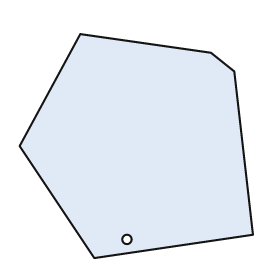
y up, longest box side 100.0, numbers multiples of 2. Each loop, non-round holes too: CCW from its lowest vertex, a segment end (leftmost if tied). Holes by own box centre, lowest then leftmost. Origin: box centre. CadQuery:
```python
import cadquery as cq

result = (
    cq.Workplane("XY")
    .moveTo(-18.0, -48.0)
    .lineTo(50.0, -38.0)
    .lineTo(42.0, 32.0)
    .lineTo(32.0, 40.0)
    .lineTo(-24.0, 48.0)
    .lineTo(-50.0, 0.0)
    .close()
    .moveTo(-4.0, -40.0)
    .circle(2.0)
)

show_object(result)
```